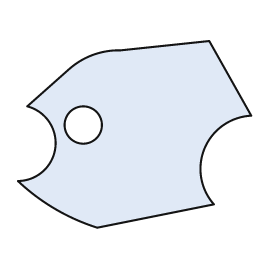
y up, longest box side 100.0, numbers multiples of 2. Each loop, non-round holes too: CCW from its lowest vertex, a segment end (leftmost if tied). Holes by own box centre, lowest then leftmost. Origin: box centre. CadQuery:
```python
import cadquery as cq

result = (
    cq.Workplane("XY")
    .moveTo(-16.0, -40.0)
    .lineTo(34.0, -30.0)
    .threePointArc((30.0, -6.0), (50.0, 8.0))
    .lineTo(32.0, 40.0)
    .lineTo(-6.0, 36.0)
    .threePointArc((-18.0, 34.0), (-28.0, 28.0))
    .lineTo(-46.0, 12.0)
    .threePointArc((-34.0, -6.0), (-50.0, -20.0))
    .threePointArc((-34.0, -32.0), (-16.0, -40.0))
    .close()
    .moveTo(-22.0, 4.0)
    .circle(8.0)
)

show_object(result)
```